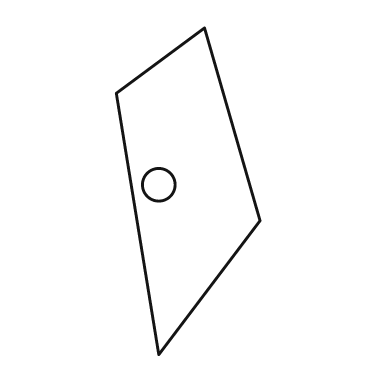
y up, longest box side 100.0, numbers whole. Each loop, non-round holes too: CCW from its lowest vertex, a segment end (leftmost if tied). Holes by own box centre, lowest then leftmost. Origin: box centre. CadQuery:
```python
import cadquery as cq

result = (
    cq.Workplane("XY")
    .moveTo(-9.0, -50.0)
    .lineTo(22.0, -9.0)
    .lineTo(5.0, 50.0)
    .lineTo(-22.0, 30.0)
    .close()
    .moveTo(-9.0, 2.0)
    .circle(5.0)
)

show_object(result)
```